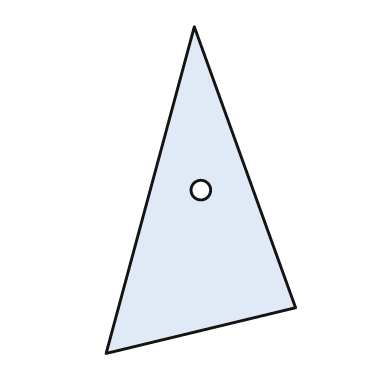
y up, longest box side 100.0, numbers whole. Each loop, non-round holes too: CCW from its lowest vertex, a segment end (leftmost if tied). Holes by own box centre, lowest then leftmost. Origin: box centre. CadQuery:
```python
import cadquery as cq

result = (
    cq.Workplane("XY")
    .moveTo(-29.0, -50.0)
    .lineTo(29.0, -36.0)
    .lineTo(-2.0, 50.0)
    .close()
    .moveTo(0.0, 0.0)
    .circle(3.0)
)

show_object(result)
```